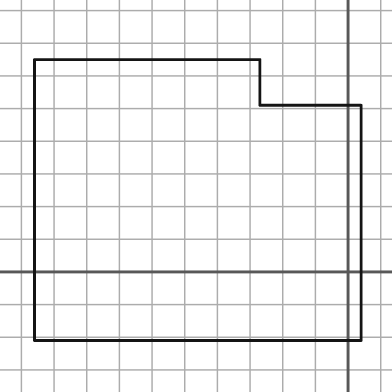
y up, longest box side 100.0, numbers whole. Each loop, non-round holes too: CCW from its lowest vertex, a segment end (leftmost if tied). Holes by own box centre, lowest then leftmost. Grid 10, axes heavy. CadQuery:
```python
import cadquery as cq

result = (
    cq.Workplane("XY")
    .moveTo(-96.0, -21.0)
    .lineTo(4.0, -21.0)
    .lineTo(4.0, 51.0)
    .lineTo(-27.0, 51.0)
    .lineTo(-27.0, 65.0)
    .lineTo(-96.0, 65.0)
    .close()
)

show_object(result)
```